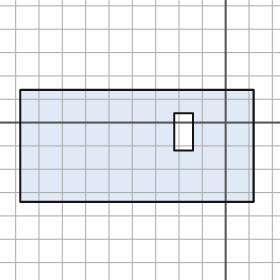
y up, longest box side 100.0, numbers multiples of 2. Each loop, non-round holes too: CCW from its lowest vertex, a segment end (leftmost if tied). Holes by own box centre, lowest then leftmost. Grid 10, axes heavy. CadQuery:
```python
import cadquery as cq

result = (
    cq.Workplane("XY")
    .moveTo(-88.0, -34.0)
    .lineTo(12.0, -34.0)
    .lineTo(12.0, 14.0)
    .lineTo(-88.0, 14.0)
    .close()
    .moveTo(-22.0, -12.0)
    .lineTo(-14.0, -12.0)
    .lineTo(-14.0, 4.0)
    .lineTo(-22.0, 4.0)
    .close()
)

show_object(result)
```